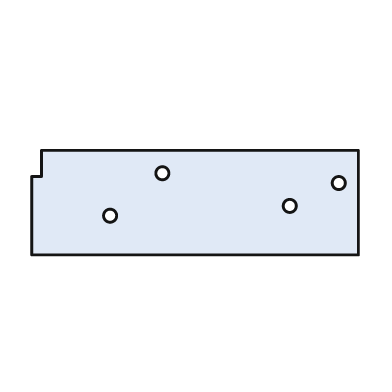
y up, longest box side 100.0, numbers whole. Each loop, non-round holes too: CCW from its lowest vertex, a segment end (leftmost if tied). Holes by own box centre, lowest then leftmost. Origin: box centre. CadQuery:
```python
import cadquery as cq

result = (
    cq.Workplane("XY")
    .moveTo(-50.0, -16.0)
    .lineTo(50.0, -16.0)
    .lineTo(50.0, 16.0)
    .lineTo(-47.0, 16.0)
    .lineTo(-47.0, 8.0)
    .lineTo(-50.0, 8.0)
    .close()
    .moveTo(-26.0, -4.0)
    .circle(2.0)
    .moveTo(29.0, -1.0)
    .circle(2.0)
    .moveTo(44.0, 6.0)
    .circle(2.0)
    .moveTo(-10.0, 9.0)
    .circle(2.0)
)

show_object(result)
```